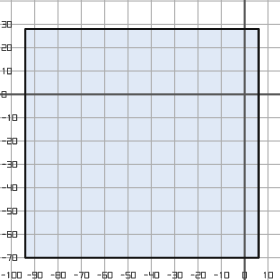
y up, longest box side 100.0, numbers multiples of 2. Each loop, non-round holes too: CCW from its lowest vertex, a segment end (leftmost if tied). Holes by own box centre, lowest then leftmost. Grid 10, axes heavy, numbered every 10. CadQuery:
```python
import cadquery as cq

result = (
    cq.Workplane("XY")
    .moveTo(-94.0, -70.0)
    .lineTo(6.0, -70.0)
    .lineTo(6.0, 28.0)
    .lineTo(-94.0, 28.0)
    .close()
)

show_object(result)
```